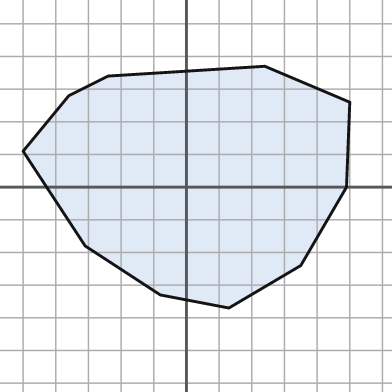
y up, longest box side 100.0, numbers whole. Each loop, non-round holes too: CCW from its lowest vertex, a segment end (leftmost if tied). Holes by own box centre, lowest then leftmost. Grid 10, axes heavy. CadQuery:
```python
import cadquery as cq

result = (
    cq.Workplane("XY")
    .moveTo(13.0, -37.0)
    .lineTo(35.0, -24.0)
    .lineTo(49.0, 0.0)
    .lineTo(50.0, 26.0)
    .lineTo(24.0, 37.0)
    .lineTo(-24.0, 34.0)
    .lineTo(-36.0, 28.0)
    .lineTo(-50.0, 11.0)
    .lineTo(-31.0, -18.0)
    .lineTo(-8.0, -33.0)
    .close()
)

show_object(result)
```